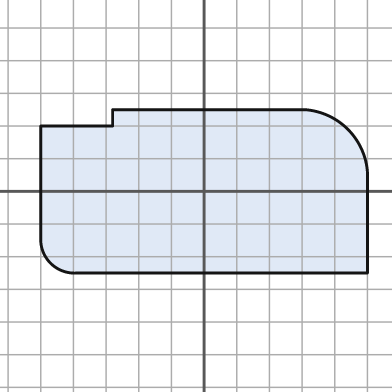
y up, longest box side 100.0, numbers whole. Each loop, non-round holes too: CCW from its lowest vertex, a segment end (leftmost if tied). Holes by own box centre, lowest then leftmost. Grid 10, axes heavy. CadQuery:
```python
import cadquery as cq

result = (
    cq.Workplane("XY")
    .moveTo(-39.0, -25.0)
    .lineTo(50.0, -25.0)
    .lineTo(50.0, 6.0)
    .threePointArc((44.0, 19.0), (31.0, 25.0))
    .lineTo(-28.0, 25.0)
    .lineTo(-28.0, 20.0)
    .lineTo(-50.0, 20.0)
    .lineTo(-50.0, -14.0)
    .threePointArc((-47.0, -22.0), (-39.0, -25.0))
    .close()
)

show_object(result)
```